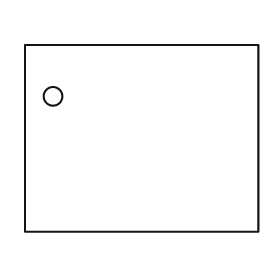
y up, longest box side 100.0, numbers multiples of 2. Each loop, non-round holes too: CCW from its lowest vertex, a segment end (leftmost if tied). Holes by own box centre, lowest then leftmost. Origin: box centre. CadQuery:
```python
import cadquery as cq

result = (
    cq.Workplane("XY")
    .moveTo(-50.0, -40.0)
    .lineTo(50.0, -40.0)
    .lineTo(50.0, 40.0)
    .lineTo(-50.0, 40.0)
    .close()
    .moveTo(-38.0, 18.0)
    .circle(4.0)
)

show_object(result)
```